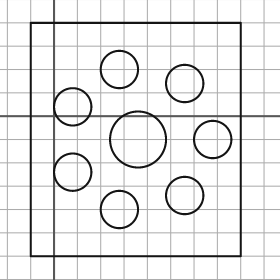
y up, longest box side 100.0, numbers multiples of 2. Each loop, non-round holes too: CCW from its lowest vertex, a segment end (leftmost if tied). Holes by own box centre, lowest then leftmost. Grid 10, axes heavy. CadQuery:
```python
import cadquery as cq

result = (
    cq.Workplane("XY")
    .moveTo(-10.0, -60.0)
    .lineTo(80.0, -60.0)
    .lineTo(80.0, 40.0)
    .lineTo(-10.0, 40.0)
    .close()
    .moveTo(28.0, -40.0)
    .circle(8.0)
    .moveTo(56.0, -34.0)
    .circle(8.0)
    .moveTo(8.0, -24.0)
    .circle(8.0)
    .moveTo(36.0, -10.0)
    .circle(12.0)
    .moveTo(68.0, -10.0)
    .circle(8.0)
    .moveTo(8.0, 4.0)
    .circle(8.0)
    .moveTo(56.0, 14.0)
    .circle(8.0)
    .moveTo(28.0, 20.0)
    .circle(8.0)
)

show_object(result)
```